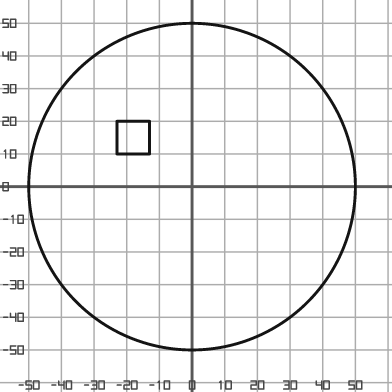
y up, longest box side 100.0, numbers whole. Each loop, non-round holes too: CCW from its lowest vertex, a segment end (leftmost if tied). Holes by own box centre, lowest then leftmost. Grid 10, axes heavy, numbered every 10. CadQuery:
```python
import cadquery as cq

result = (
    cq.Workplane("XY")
    .moveTo(0.0, 0.0)
    .circle(50.0)
    .moveTo(-23.0, 10.0)
    .lineTo(-13.0, 10.0)
    .lineTo(-13.0, 20.0)
    .lineTo(-23.0, 20.0)
    .close()
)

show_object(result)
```